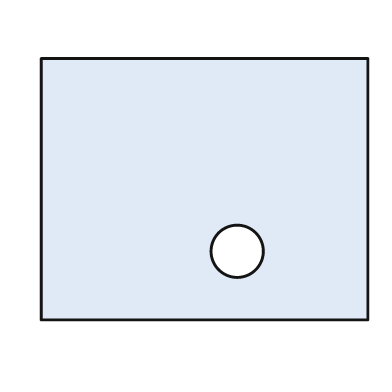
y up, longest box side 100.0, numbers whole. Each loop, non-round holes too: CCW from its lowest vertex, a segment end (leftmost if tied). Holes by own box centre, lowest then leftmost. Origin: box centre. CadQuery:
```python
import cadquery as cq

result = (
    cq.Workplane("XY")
    .moveTo(-50.0, -40.0)
    .lineTo(50.0, -40.0)
    .lineTo(50.0, 40.0)
    .lineTo(-50.0, 40.0)
    .close()
    .moveTo(10.0, -19.0)
    .circle(8.0)
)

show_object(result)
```